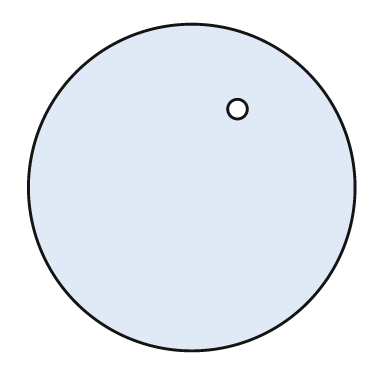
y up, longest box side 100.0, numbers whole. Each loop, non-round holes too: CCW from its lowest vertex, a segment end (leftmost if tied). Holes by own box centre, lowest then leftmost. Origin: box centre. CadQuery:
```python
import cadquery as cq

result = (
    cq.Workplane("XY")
    .moveTo(0.0, 0.0)
    .circle(50.0)
    .moveTo(14.0, 24.0)
    .circle(3.0)
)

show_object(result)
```